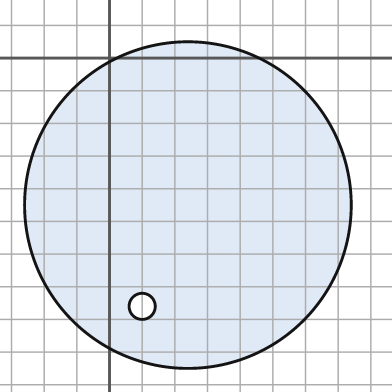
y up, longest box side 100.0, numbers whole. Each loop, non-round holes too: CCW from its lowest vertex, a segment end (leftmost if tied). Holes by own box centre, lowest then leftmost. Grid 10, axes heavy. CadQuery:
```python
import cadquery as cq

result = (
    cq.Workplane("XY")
    .moveTo(24.0, -45.0)
    .circle(50.0)
    .moveTo(10.0, -76.0)
    .circle(4.0)
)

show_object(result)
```